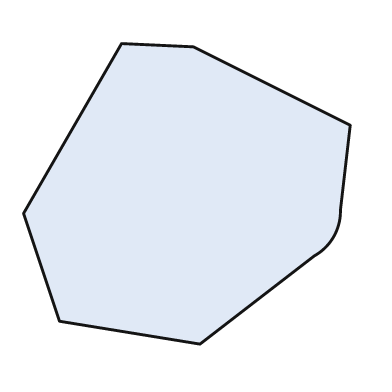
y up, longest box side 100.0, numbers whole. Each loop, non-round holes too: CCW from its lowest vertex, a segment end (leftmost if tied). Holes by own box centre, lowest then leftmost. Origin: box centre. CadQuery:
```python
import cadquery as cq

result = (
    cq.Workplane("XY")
    .moveTo(4.0, -46.0)
    .lineTo(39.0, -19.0)
    .threePointArc((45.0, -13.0), (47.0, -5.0))
    .lineTo(50.0, 21.0)
    .lineTo(2.0, 45.0)
    .lineTo(-20.0, 46.0)
    .lineTo(-50.0, -6.0)
    .lineTo(-39.0, -39.0)
    .close()
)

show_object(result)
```